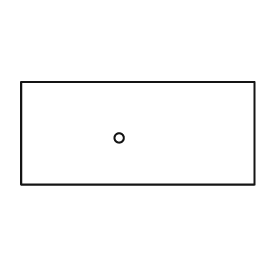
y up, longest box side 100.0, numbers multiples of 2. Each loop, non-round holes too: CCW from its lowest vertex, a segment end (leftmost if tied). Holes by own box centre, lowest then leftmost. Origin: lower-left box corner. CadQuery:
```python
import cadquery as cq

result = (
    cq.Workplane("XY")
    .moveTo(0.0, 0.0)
    .lineTo(100.0, 0.0)
    .lineTo(100.0, 44.0)
    .lineTo(0.0, 44.0)
    .close()
    .moveTo(42.0, 20.0)
    .circle(2.0)
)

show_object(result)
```